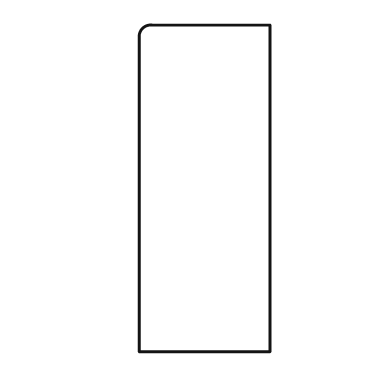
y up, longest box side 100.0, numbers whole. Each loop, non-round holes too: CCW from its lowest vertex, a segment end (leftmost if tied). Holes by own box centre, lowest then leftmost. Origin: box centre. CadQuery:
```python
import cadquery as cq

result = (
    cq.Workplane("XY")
    .moveTo(-20.0, -50.0)
    .lineTo(20.0, -50.0)
    .lineTo(20.0, 50.0)
    .lineTo(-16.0, 50.0)
    .threePointArc((-19.0, 49.0), (-20.0, 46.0))
    .close()
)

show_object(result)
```